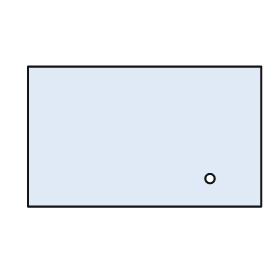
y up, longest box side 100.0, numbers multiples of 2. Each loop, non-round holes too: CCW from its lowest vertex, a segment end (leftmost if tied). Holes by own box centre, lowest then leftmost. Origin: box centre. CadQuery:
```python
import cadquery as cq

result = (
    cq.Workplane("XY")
    .moveTo(-50.0, -30.0)
    .lineTo(50.0, -30.0)
    .lineTo(50.0, 30.0)
    .lineTo(-50.0, 30.0)
    .close()
    .moveTo(28.0, -18.0)
    .circle(2.0)
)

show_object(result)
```